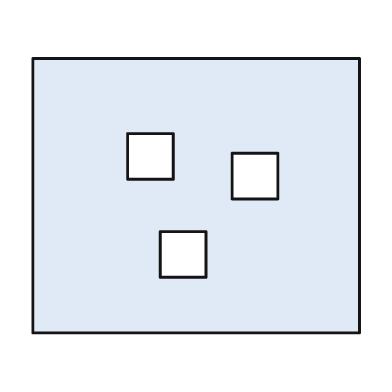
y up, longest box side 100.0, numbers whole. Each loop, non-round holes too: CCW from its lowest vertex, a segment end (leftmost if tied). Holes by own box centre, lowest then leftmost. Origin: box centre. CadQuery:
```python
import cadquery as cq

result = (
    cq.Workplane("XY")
    .moveTo(-50.0, -42.0)
    .lineTo(50.0, -42.0)
    .lineTo(50.0, 42.0)
    .lineTo(-50.0, 42.0)
    .close()
    .moveTo(-11.0, -25.0)
    .lineTo(3.0, -25.0)
    .lineTo(3.0, -11.0)
    .lineTo(-11.0, -11.0)
    .close()
    .moveTo(11.0, -1.0)
    .lineTo(25.0, -1.0)
    .lineTo(25.0, 13.0)
    .lineTo(11.0, 13.0)
    .close()
    .moveTo(-21.0, 5.0)
    .lineTo(-7.0, 5.0)
    .lineTo(-7.0, 19.0)
    .lineTo(-21.0, 19.0)
    .close()
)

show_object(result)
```